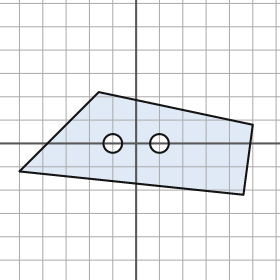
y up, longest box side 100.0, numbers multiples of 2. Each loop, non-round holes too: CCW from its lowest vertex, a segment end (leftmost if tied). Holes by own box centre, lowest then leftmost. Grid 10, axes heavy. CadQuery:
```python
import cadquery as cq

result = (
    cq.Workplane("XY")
    .moveTo(46.0, -22.0)
    .lineTo(50.0, 8.0)
    .lineTo(-16.0, 22.0)
    .lineTo(-50.0, -12.0)
    .close()
    .moveTo(-10.0, 0.0)
    .circle(4.0)
    .moveTo(10.0, 0.0)
    .circle(4.0)
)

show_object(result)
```